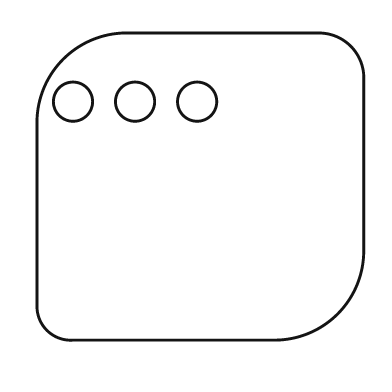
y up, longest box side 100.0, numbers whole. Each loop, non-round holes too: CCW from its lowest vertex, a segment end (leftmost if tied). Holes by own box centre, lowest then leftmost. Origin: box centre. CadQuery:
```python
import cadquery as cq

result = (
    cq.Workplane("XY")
    .moveTo(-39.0, -47.0)
    .lineTo(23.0, -47.0)
    .threePointArc((42.0, -39.0), (50.0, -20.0))
    .lineTo(50.0, 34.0)
    .threePointArc((46.0, 43.0), (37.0, 47.0))
    .lineTo(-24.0, 47.0)
    .threePointArc((-42.0, 39.0), (-50.0, 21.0))
    .lineTo(-50.0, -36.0)
    .threePointArc((-47.0, -44.0), (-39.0, -47.0))
    .close()
    .moveTo(-39.0, 26.0)
    .circle(6.0)
    .moveTo(-20.0, 26.0)
    .circle(6.0)
    .moveTo(-1.0, 26.0)
    .circle(6.0)
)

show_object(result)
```